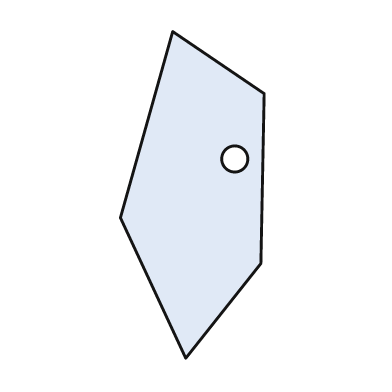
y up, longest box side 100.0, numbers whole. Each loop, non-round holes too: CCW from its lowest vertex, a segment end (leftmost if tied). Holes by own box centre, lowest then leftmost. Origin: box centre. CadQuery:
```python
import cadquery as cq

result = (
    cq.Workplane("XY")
    .moveTo(-2.0, -50.0)
    .lineTo(21.0, -21.0)
    .lineTo(22.0, 31.0)
    .lineTo(-6.0, 50.0)
    .lineTo(-22.0, -7.0)
    .close()
    .moveTo(13.0, 11.0)
    .circle(4.0)
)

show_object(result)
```